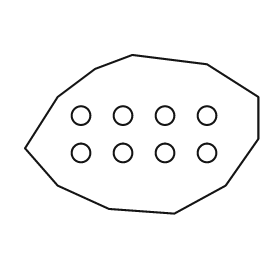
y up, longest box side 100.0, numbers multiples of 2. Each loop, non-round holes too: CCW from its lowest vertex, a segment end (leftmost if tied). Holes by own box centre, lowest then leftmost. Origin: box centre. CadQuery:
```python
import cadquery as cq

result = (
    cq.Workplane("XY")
    .moveTo(14.0, -34.0)
    .lineTo(36.0, -22.0)
    .lineTo(50.0, -2.0)
    .lineTo(50.0, 16.0)
    .lineTo(28.0, 30.0)
    .lineTo(-4.0, 34.0)
    .lineTo(-20.0, 28.0)
    .lineTo(-36.0, 16.0)
    .lineTo(-50.0, -6.0)
    .lineTo(-36.0, -22.0)
    .lineTo(-14.0, -32.0)
    .close()
    .moveTo(-26.0, -8.0)
    .circle(4.0)
    .moveTo(-8.0, -8.0)
    .circle(4.0)
    .moveTo(10.0, -8.0)
    .circle(4.0)
    .moveTo(28.0, -8.0)
    .circle(4.0)
    .moveTo(-26.0, 8.0)
    .circle(4.0)
    .moveTo(-8.0, 8.0)
    .circle(4.0)
    .moveTo(10.0, 8.0)
    .circle(4.0)
    .moveTo(28.0, 8.0)
    .circle(4.0)
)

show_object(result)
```